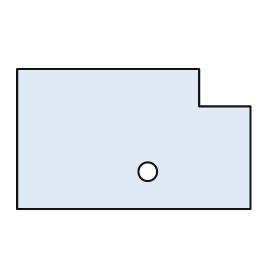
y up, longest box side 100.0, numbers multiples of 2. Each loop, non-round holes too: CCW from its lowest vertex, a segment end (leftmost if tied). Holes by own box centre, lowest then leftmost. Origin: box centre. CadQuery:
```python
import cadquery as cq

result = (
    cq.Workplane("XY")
    .moveTo(-50.0, -30.0)
    .lineTo(50.0, -30.0)
    .lineTo(50.0, 14.0)
    .lineTo(28.0, 14.0)
    .lineTo(28.0, 30.0)
    .lineTo(-50.0, 30.0)
    .close()
    .moveTo(6.0, -14.0)
    .circle(4.0)
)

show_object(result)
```